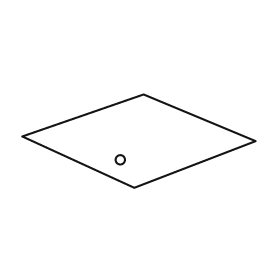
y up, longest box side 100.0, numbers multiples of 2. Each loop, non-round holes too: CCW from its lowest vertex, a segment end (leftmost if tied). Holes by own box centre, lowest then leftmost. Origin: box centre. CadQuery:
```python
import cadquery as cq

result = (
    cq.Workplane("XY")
    .moveTo(-2.0, -20.0)
    .lineTo(50.0, 0.0)
    .lineTo(2.0, 20.0)
    .lineTo(-50.0, 2.0)
    .close()
    .moveTo(-8.0, -8.0)
    .circle(2.0)
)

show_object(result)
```